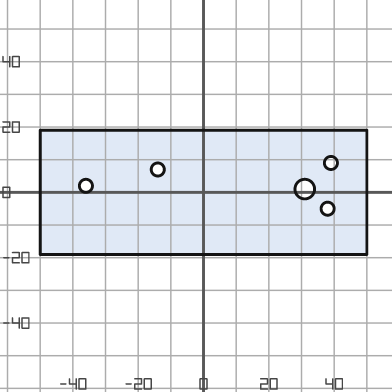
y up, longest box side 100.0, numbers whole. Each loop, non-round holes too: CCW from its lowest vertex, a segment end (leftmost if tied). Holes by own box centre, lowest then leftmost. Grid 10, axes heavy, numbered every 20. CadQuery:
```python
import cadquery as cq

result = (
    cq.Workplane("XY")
    .moveTo(-50.0, -19.0)
    .lineTo(50.0, -19.0)
    .lineTo(50.0, 19.0)
    .lineTo(-50.0, 19.0)
    .close()
    .moveTo(38.0, -5.0)
    .circle(2.0)
    .moveTo(31.0, 1.0)
    .circle(3.0)
    .moveTo(-36.0, 2.0)
    .circle(2.0)
    .moveTo(-14.0, 7.0)
    .circle(2.0)
    .moveTo(39.0, 9.0)
    .circle(2.0)
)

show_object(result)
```